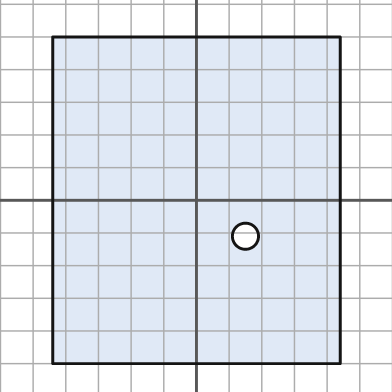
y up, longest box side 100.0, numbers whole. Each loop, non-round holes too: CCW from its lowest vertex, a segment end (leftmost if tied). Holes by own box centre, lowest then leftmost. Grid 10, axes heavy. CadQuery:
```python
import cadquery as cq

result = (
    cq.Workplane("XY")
    .moveTo(-44.0, -50.0)
    .lineTo(44.0, -50.0)
    .lineTo(44.0, 50.0)
    .lineTo(-44.0, 50.0)
    .close()
    .moveTo(15.0, -11.0)
    .circle(4.0)
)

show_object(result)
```